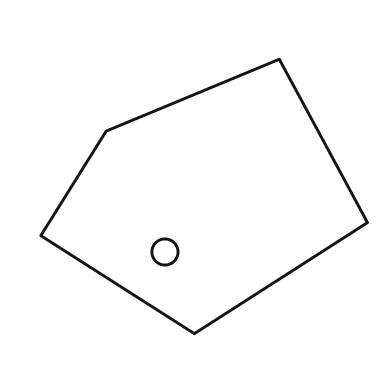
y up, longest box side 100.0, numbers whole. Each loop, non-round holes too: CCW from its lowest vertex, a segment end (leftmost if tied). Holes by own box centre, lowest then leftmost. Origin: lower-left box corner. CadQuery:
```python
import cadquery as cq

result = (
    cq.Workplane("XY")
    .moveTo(47.0, 0.0)
    .lineTo(100.0, 34.0)
    .lineTo(73.0, 84.0)
    .lineTo(20.0, 62.0)
    .lineTo(0.0, 30.0)
    .close()
    .moveTo(38.0, 25.0)
    .circle(4.0)
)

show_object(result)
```